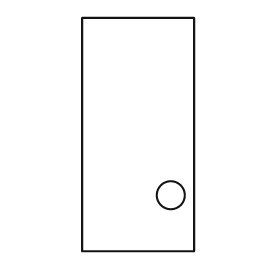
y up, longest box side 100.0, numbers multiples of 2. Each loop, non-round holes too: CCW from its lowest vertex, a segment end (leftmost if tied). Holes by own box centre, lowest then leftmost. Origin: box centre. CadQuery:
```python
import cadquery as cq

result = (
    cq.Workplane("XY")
    .moveTo(-24.0, -50.0)
    .lineTo(24.0, -50.0)
    .lineTo(24.0, 50.0)
    .lineTo(-24.0, 50.0)
    .close()
    .moveTo(14.0, -26.0)
    .circle(6.0)
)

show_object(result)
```